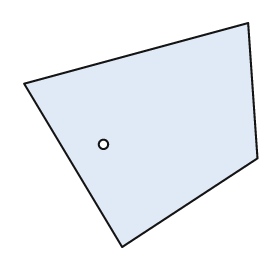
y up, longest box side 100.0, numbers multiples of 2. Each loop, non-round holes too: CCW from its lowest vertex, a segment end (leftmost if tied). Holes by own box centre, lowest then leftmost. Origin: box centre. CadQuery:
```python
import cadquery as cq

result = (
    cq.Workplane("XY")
    .moveTo(-8.0, -48.0)
    .lineTo(50.0, -10.0)
    .lineTo(46.0, 48.0)
    .lineTo(-50.0, 22.0)
    .close()
    .moveTo(-16.0, -4.0)
    .circle(2.0)
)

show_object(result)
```